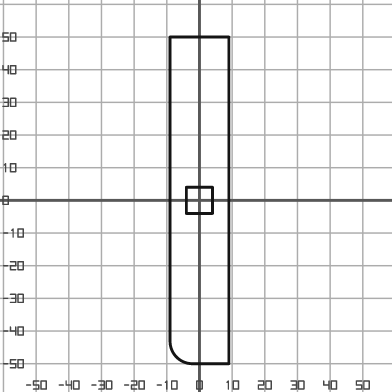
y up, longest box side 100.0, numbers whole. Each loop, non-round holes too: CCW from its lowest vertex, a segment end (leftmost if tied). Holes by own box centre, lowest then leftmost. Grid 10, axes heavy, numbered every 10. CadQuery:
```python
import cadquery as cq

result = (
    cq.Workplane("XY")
    .moveTo(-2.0, -50.0)
    .lineTo(9.0, -50.0)
    .lineTo(9.0, 50.0)
    .lineTo(-9.0, 50.0)
    .lineTo(-9.0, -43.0)
    .threePointArc((-7.0, -48.0), (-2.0, -50.0))
    .close()
    .moveTo(-4.0, -4.0)
    .lineTo(4.0, -4.0)
    .lineTo(4.0, 4.0)
    .lineTo(-4.0, 4.0)
    .close()
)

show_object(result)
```